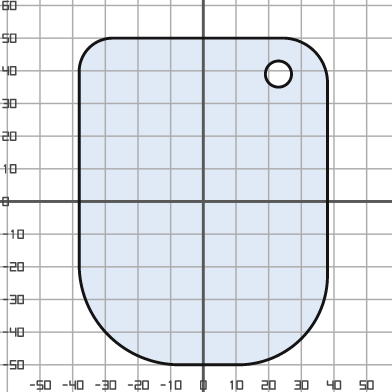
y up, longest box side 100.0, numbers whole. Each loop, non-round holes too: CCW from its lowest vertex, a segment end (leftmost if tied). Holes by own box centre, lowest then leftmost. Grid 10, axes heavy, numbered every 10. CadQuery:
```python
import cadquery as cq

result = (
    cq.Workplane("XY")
    .moveTo(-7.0, -50.0)
    .lineTo(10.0, -50.0)
    .threePointArc((30.0, -42.0), (38.0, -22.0))
    .lineTo(38.0, 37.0)
    .threePointArc((34.0, 46.0), (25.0, 50.0))
    .lineTo(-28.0, 50.0)
    .threePointArc((-35.0, 47.0), (-38.0, 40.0))
    .lineTo(-38.0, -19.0)
    .threePointArc((-29.0, -41.0), (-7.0, -50.0))
    .close()
    .moveTo(23.0, 39.0)
    .circle(4.0)
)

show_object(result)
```